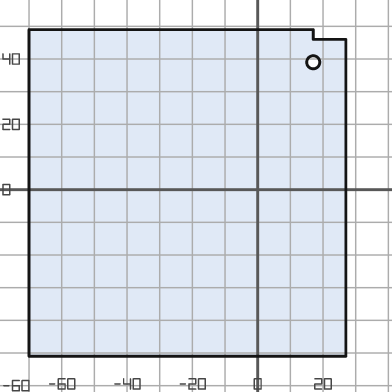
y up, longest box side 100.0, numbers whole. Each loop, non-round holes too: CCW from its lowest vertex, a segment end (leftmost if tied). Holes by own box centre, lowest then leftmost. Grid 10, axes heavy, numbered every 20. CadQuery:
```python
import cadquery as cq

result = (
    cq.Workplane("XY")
    .moveTo(-70.0, -51.0)
    .lineTo(27.0, -51.0)
    .lineTo(27.0, 46.0)
    .lineTo(17.0, 46.0)
    .lineTo(17.0, 49.0)
    .lineTo(-70.0, 49.0)
    .close()
    .moveTo(17.0, 39.0)
    .circle(2.0)
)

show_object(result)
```